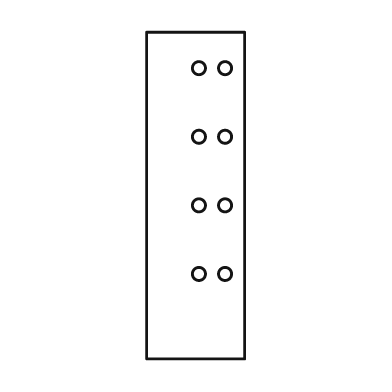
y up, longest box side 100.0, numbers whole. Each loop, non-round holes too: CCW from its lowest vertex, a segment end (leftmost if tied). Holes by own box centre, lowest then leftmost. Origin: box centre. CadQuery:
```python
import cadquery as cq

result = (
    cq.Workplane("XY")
    .moveTo(-15.0, -50.0)
    .lineTo(15.0, -50.0)
    .lineTo(15.0, 50.0)
    .lineTo(-15.0, 50.0)
    .close()
    .moveTo(1.0, -24.0)
    .circle(2.0)
    .moveTo(9.0, -24.0)
    .circle(2.0)
    .moveTo(1.0, -3.0)
    .circle(2.0)
    .moveTo(9.0, -3.0)
    .circle(2.0)
    .moveTo(1.0, 18.0)
    .circle(2.0)
    .moveTo(9.0, 18.0)
    .circle(2.0)
    .moveTo(1.0, 39.0)
    .circle(2.0)
    .moveTo(9.0, 39.0)
    .circle(2.0)
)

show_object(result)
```